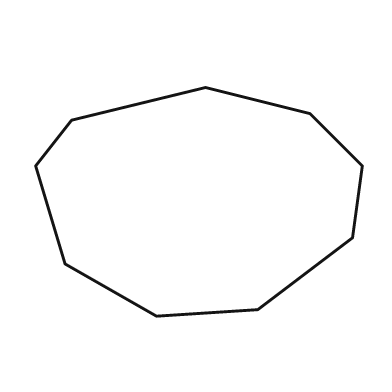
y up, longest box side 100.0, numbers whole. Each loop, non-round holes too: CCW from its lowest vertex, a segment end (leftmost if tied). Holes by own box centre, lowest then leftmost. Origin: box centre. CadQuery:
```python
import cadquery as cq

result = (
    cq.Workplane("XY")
    .moveTo(-13.0, -35.0)
    .lineTo(18.0, -33.0)
    .lineTo(47.0, -11.0)
    .lineTo(50.0, 11.0)
    .lineTo(34.0, 27.0)
    .lineTo(2.0, 35.0)
    .lineTo(-39.0, 25.0)
    .lineTo(-50.0, 11.0)
    .lineTo(-41.0, -19.0)
    .close()
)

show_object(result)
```